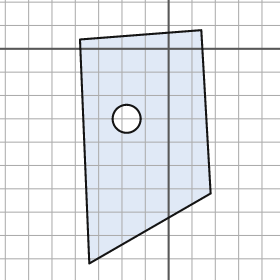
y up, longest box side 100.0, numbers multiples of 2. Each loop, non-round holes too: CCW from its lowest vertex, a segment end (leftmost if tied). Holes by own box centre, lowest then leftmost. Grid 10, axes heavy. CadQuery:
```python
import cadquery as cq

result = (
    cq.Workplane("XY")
    .moveTo(-34.0, -92.0)
    .lineTo(18.0, -62.0)
    .lineTo(14.0, 8.0)
    .lineTo(-38.0, 4.0)
    .close()
    .moveTo(-18.0, -30.0)
    .circle(6.0)
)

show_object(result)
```